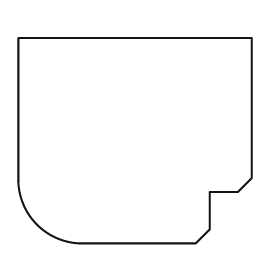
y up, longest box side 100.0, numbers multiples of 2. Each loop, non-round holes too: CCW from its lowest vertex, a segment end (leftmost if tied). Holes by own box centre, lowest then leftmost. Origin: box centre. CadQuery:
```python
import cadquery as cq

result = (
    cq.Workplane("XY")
    .moveTo(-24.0, -44.0)
    .lineTo(26.0, -44.0)
    .lineTo(32.0, -38.0)
    .lineTo(32.0, -22.0)
    .lineTo(44.0, -22.0)
    .lineTo(50.0, -16.0)
    .lineTo(50.0, 44.0)
    .lineTo(-50.0, 44.0)
    .lineTo(-50.0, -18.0)
    .threePointArc((-42.0, -36.0), (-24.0, -44.0))
    .close()
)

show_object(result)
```